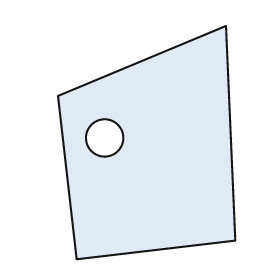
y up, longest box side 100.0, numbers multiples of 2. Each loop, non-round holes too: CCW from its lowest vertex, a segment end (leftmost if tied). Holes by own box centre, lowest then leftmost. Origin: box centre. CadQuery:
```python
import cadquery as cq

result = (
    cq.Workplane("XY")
    .moveTo(-30.0, -50.0)
    .lineTo(38.0, -42.0)
    .lineTo(34.0, 50.0)
    .lineTo(-38.0, 20.0)
    .close()
    .moveTo(-18.0, 2.0)
    .circle(8.0)
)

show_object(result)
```